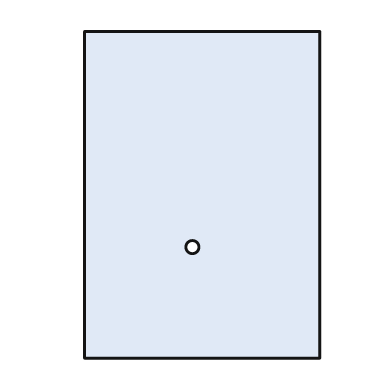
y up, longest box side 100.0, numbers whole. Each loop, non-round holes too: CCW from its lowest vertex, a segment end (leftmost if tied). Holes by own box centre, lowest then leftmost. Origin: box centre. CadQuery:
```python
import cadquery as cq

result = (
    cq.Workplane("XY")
    .moveTo(-36.0, -50.0)
    .lineTo(36.0, -50.0)
    .lineTo(36.0, 50.0)
    .lineTo(-36.0, 50.0)
    .close()
    .moveTo(-3.0, -16.0)
    .circle(2.0)
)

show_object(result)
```